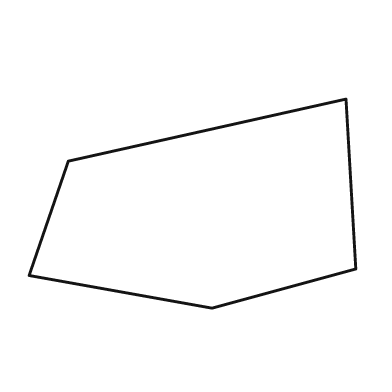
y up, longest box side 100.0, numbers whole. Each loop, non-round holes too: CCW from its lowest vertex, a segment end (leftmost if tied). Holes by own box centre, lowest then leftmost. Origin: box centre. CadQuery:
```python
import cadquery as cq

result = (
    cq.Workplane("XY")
    .moveTo(6.0, -32.0)
    .lineTo(50.0, -20.0)
    .lineTo(47.0, 32.0)
    .lineTo(-38.0, 13.0)
    .lineTo(-50.0, -22.0)
    .close()
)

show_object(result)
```